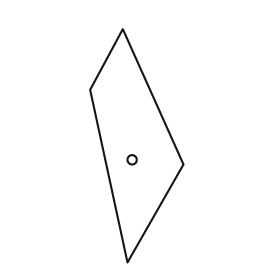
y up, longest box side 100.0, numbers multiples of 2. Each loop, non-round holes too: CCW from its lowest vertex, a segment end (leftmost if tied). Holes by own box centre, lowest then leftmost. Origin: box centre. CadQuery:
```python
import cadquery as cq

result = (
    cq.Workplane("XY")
    .moveTo(-4.0, -50.0)
    .lineTo(20.0, -8.0)
    .lineTo(-6.0, 50.0)
    .lineTo(-20.0, 24.0)
    .close()
    .moveTo(-2.0, -6.0)
    .circle(2.0)
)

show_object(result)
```